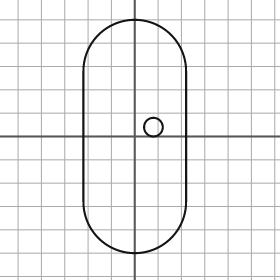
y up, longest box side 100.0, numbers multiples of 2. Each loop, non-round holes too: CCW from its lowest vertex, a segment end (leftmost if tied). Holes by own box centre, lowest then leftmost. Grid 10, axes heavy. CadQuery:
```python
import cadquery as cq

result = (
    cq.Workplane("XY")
    .moveTo(-22.0, -28.0)
    .threePointArc((0.0, -50.0), (22.0, -28.0))
    .lineTo(22.0, 28.0)
    .threePointArc((0.0, 50.0), (-22.0, 28.0))
    .close()
    .moveTo(8.0, 4.0)
    .circle(4.0)
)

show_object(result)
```